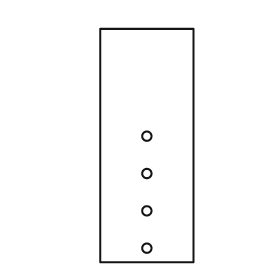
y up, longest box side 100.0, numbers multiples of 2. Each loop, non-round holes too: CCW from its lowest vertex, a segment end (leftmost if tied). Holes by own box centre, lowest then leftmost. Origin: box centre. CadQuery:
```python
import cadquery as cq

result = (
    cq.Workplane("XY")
    .moveTo(-20.0, -50.0)
    .lineTo(20.0, -50.0)
    .lineTo(20.0, 50.0)
    .lineTo(-20.0, 50.0)
    .close()
    .moveTo(0.0, -44.0)
    .circle(2.0)
    .moveTo(0.0, -28.0)
    .circle(2.0)
    .moveTo(0.0, -12.0)
    .circle(2.0)
    .moveTo(0.0, 4.0)
    .circle(2.0)
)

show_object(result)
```